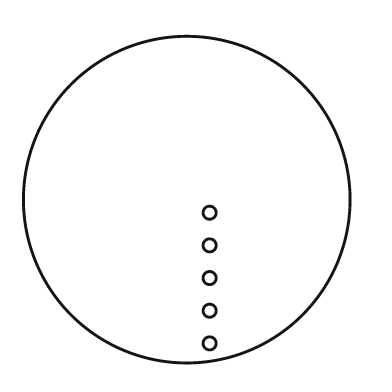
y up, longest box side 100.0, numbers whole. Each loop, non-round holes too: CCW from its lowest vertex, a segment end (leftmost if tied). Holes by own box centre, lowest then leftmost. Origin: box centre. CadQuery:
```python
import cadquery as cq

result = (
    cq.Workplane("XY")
    .moveTo(0.0, 0.0)
    .circle(50.0)
    .moveTo(7.0, -44.0)
    .circle(2.0)
    .moveTo(7.0, -34.0)
    .circle(2.0)
    .moveTo(7.0, -24.0)
    .circle(2.0)
    .moveTo(7.0, -14.0)
    .circle(2.0)
    .moveTo(7.0, -4.0)
    .circle(2.0)
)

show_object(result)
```